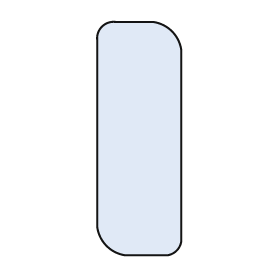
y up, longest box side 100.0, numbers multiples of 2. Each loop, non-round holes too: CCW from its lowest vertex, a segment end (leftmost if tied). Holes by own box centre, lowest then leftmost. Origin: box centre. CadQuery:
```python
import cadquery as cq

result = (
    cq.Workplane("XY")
    .moveTo(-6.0, -50.0)
    .lineTo(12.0, -50.0)
    .threePointArc((16.0, -48.0), (18.0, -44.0))
    .lineTo(18.0, 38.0)
    .threePointArc((14.0, 46.0), (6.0, 50.0))
    .lineTo(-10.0, 50.0)
    .threePointArc((-16.0, 48.0), (-18.0, 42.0))
    .lineTo(-18.0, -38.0)
    .threePointArc((-14.0, -46.0), (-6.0, -50.0))
    .close()
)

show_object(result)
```